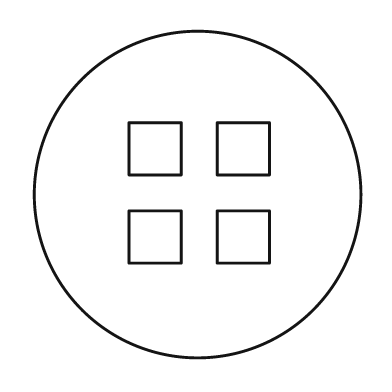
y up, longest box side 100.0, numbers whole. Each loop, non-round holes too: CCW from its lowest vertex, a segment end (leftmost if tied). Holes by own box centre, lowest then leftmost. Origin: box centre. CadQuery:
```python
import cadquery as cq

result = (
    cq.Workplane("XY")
    .moveTo(0.0, 0.0)
    .circle(50.0)
    .moveTo(-21.0, -21.0)
    .lineTo(-5.0, -21.0)
    .lineTo(-5.0, -5.0)
    .lineTo(-21.0, -5.0)
    .close()
    .moveTo(6.0, -21.0)
    .lineTo(22.0, -21.0)
    .lineTo(22.0, -5.0)
    .lineTo(6.0, -5.0)
    .close()
    .moveTo(-21.0, 6.0)
    .lineTo(-5.0, 6.0)
    .lineTo(-5.0, 22.0)
    .lineTo(-21.0, 22.0)
    .close()
    .moveTo(6.0, 6.0)
    .lineTo(22.0, 6.0)
    .lineTo(22.0, 22.0)
    .lineTo(6.0, 22.0)
    .close()
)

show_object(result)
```